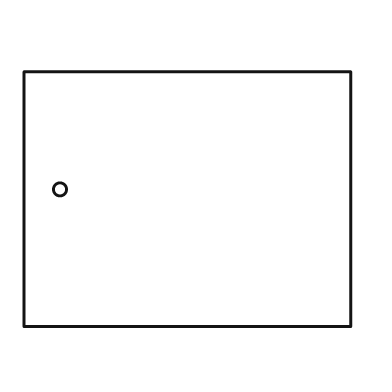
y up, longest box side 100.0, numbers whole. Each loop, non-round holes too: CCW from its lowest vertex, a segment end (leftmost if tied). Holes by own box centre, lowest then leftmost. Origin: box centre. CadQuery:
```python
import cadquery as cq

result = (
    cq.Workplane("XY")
    .moveTo(-50.0, -39.0)
    .lineTo(50.0, -39.0)
    .lineTo(50.0, 39.0)
    .lineTo(-50.0, 39.0)
    .close()
    .moveTo(-39.0, 3.0)
    .circle(2.0)
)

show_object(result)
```